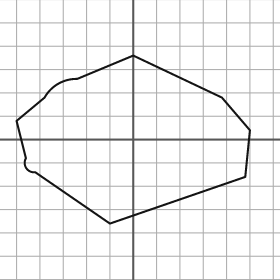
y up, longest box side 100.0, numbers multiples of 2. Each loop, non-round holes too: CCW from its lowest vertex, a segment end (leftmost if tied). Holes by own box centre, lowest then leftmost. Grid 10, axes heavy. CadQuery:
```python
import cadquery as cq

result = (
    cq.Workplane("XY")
    .moveTo(-10.0, -36.0)
    .lineTo(48.0, -16.0)
    .lineTo(50.0, 4.0)
    .lineTo(38.0, 18.0)
    .lineTo(0.0, 36.0)
    .lineTo(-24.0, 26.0)
    .threePointArc((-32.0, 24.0), (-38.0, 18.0))
    .lineTo(-50.0, 8.0)
    .lineTo(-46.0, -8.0)
    .threePointArc((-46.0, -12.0), (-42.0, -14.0))
    .close()
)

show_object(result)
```